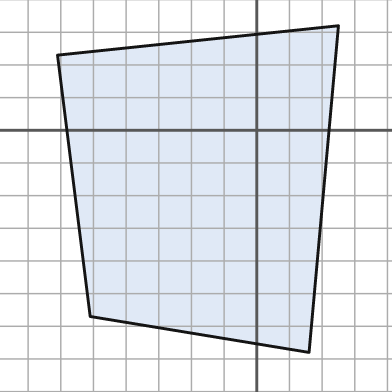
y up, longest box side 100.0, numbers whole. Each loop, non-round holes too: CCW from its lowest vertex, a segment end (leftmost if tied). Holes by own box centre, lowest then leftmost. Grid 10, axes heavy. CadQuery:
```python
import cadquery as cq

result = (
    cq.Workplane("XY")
    .moveTo(16.0, -68.0)
    .lineTo(25.0, 32.0)
    .lineTo(-61.0, 23.0)
    .lineTo(-51.0, -57.0)
    .close()
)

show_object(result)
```